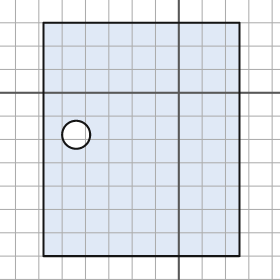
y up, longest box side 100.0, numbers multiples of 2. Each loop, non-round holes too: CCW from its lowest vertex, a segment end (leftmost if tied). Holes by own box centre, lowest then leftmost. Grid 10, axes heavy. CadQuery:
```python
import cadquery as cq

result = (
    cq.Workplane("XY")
    .moveTo(-58.0, -70.0)
    .lineTo(26.0, -70.0)
    .lineTo(26.0, 30.0)
    .lineTo(-58.0, 30.0)
    .close()
    .moveTo(-44.0, -18.0)
    .circle(6.0)
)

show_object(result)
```